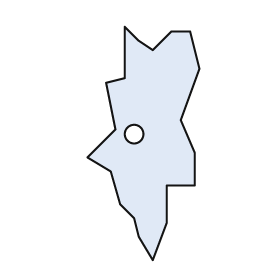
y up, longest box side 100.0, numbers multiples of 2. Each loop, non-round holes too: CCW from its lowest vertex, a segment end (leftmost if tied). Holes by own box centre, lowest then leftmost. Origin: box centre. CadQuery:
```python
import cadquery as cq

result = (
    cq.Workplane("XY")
    .moveTo(4.0, -50.0)
    .lineTo(10.0, -34.0)
    .lineTo(10.0, -18.0)
    .lineTo(22.0, -18.0)
    .lineTo(22.0, -4.0)
    .lineTo(16.0, 10.0)
    .lineTo(24.0, 32.0)
    .lineTo(20.0, 48.0)
    .lineTo(12.0, 48.0)
    .lineTo(4.0, 40.0)
    .lineTo(-2.0, 44.0)
    .lineTo(-8.0, 50.0)
    .lineTo(-8.0, 28.0)
    .lineTo(-16.0, 26.0)
    .lineTo(-12.0, 6.0)
    .lineTo(-24.0, -6.0)
    .lineTo(-14.0, -12.0)
    .lineTo(-10.0, -26.0)
    .lineTo(-4.0, -32.0)
    .lineTo(-2.0, -40.0)
    .close()
    .moveTo(-4.0, 4.0)
    .circle(4.0)
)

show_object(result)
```